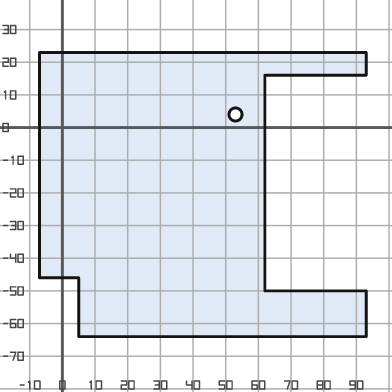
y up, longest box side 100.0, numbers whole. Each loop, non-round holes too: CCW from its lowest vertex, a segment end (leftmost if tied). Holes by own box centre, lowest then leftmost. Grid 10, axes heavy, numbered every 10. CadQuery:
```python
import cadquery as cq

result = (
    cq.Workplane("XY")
    .moveTo(5.0, -64.0)
    .lineTo(93.0, -64.0)
    .lineTo(93.0, -50.0)
    .lineTo(62.0, -50.0)
    .lineTo(62.0, 16.0)
    .lineTo(93.0, 16.0)
    .lineTo(93.0, 23.0)
    .lineTo(-7.0, 23.0)
    .lineTo(-7.0, -46.0)
    .lineTo(5.0, -46.0)
    .close()
    .moveTo(53.0, 4.0)
    .circle(2.0)
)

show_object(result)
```